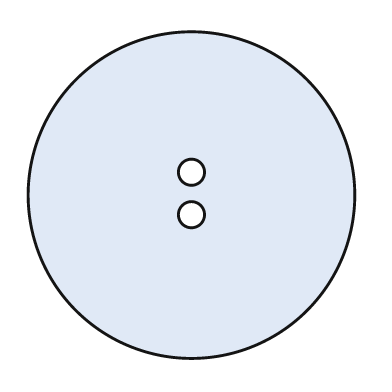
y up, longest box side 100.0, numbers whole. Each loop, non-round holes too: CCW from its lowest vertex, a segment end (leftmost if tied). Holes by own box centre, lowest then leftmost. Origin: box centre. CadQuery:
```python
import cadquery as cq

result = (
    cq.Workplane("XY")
    .moveTo(0.0, 0.0)
    .circle(50.0)
    .moveTo(0.0, -6.0)
    .circle(4.0)
    .moveTo(0.0, 7.0)
    .circle(4.0)
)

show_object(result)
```